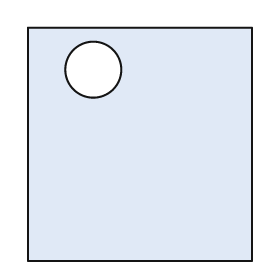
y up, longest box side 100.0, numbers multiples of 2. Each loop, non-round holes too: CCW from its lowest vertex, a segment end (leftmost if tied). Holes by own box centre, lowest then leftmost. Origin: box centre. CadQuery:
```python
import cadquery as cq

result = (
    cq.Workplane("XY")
    .moveTo(-48.0, -50.0)
    .lineTo(48.0, -50.0)
    .lineTo(48.0, 50.0)
    .lineTo(-48.0, 50.0)
    .close()
    .moveTo(-20.0, 32.0)
    .circle(12.0)
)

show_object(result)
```